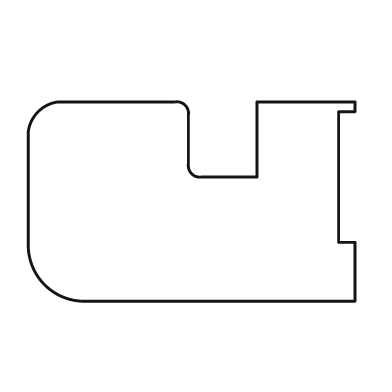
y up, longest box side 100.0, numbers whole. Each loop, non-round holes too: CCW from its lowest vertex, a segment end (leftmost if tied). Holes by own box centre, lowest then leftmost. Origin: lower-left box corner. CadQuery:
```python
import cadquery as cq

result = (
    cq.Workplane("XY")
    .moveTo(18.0, 0.0)
    .lineTo(100.0, 0.0)
    .lineTo(100.0, 18.0)
    .lineTo(95.0, 18.0)
    .lineTo(95.0, 58.0)
    .lineTo(100.0, 58.0)
    .lineTo(100.0, 61.0)
    .lineTo(70.0, 61.0)
    .lineTo(70.0, 38.0)
    .lineTo(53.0, 38.0)
    .threePointArc((50.0, 39.0), (49.0, 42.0))
    .lineTo(49.0, 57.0)
    .threePointArc((48.0, 60.0), (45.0, 61.0))
    .lineTo(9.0, 61.0)
    .threePointArc((3.0, 58.0), (0.0, 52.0))
    .lineTo(0.0, 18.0)
    .threePointArc((5.0, 5.0), (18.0, 0.0))
    .close()
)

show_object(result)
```